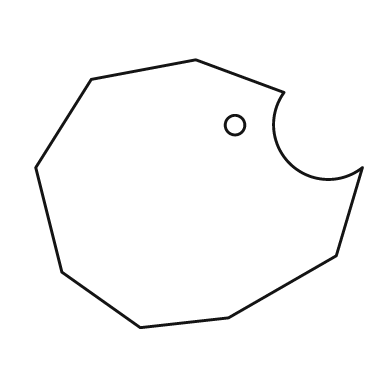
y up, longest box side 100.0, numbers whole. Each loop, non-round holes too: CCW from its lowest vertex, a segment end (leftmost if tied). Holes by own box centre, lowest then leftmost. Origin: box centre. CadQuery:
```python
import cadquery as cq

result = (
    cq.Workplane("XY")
    .moveTo(-18.0, -41.0)
    .lineTo(9.0, -38.0)
    .lineTo(42.0, -19.0)
    .lineTo(50.0, 8.0)
    .threePointArc((28.0, 9.0), (26.0, 31.0))
    .lineTo(-1.0, 41.0)
    .lineTo(-33.0, 35.0)
    .lineTo(-50.0, 8.0)
    .lineTo(-42.0, -24.0)
    .close()
    .moveTo(11.0, 21.0)
    .circle(3.0)
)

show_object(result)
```